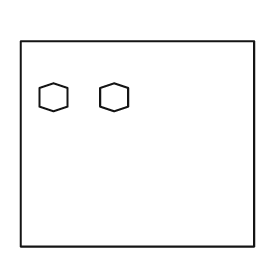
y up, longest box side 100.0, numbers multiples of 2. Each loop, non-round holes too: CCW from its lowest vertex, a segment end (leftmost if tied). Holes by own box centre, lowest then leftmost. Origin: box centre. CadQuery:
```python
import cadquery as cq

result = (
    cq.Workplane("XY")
    .moveTo(-50.0, -44.0)
    .lineTo(50.0, -44.0)
    .lineTo(50.0, 44.0)
    .lineTo(-50.0, 44.0)
    .close()
    .moveTo(-36.0, 14.0)
    .lineTo(-30.0, 16.0)
    .lineTo(-30.0, 24.0)
    .lineTo(-36.0, 26.0)
    .lineTo(-42.0, 24.0)
    .lineTo(-42.0, 16.0)
    .close()
    .moveTo(-10.0, 14.0)
    .lineTo(-4.0, 16.0)
    .lineTo(-4.0, 24.0)
    .lineTo(-10.0, 26.0)
    .lineTo(-16.0, 24.0)
    .lineTo(-16.0, 16.0)
    .close()
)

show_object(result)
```